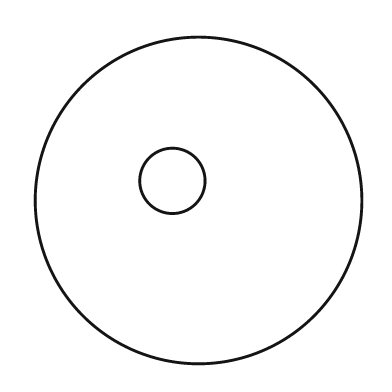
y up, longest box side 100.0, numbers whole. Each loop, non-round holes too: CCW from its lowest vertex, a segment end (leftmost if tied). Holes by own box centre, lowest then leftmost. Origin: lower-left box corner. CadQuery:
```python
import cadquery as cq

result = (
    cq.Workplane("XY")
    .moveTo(50.0, 50.0)
    .circle(50.0)
    .moveTo(42.0, 56.0)
    .circle(10.0)
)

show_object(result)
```